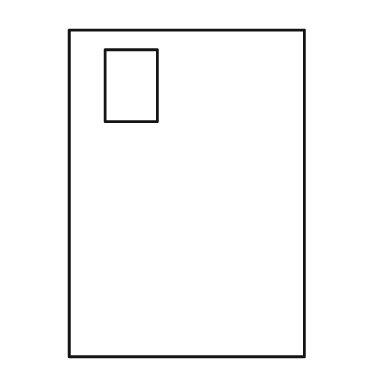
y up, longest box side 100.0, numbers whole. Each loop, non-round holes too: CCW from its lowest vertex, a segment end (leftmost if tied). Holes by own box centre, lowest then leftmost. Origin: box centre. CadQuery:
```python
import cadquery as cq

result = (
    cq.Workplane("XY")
    .moveTo(-36.0, -50.0)
    .lineTo(36.0, -50.0)
    .lineTo(36.0, 50.0)
    .lineTo(-36.0, 50.0)
    .close()
    .moveTo(-25.0, 22.0)
    .lineTo(-9.0, 22.0)
    .lineTo(-9.0, 44.0)
    .lineTo(-25.0, 44.0)
    .close()
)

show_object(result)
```